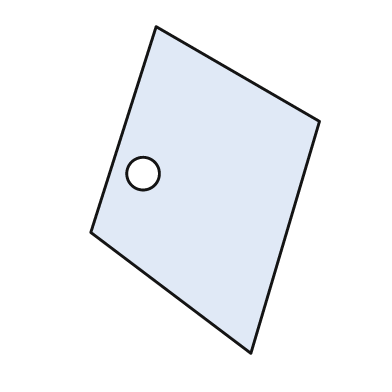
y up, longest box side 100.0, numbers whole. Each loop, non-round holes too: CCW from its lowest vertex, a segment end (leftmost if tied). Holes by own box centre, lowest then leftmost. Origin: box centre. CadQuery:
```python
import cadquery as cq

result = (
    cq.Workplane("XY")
    .moveTo(14.0, -50.0)
    .lineTo(35.0, 21.0)
    .lineTo(-15.0, 50.0)
    .lineTo(-35.0, -13.0)
    .close()
    .moveTo(-19.0, 5.0)
    .circle(5.0)
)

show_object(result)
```